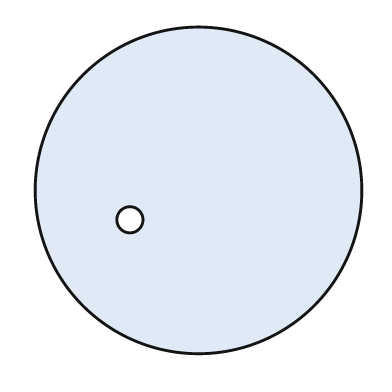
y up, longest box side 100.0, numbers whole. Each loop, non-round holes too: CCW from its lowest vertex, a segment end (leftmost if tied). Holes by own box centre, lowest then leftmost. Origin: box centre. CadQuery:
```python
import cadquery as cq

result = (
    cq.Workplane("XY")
    .moveTo(0.0, 0.0)
    .circle(50.0)
    .moveTo(-21.0, -9.0)
    .circle(4.0)
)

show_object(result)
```